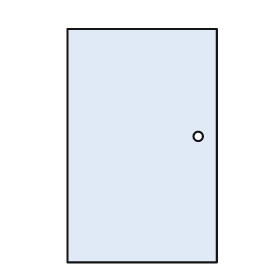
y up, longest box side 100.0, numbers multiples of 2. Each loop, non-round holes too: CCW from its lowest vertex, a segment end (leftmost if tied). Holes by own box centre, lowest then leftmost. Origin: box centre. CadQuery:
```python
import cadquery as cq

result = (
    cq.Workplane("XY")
    .moveTo(-32.0, -50.0)
    .lineTo(32.0, -50.0)
    .lineTo(32.0, 50.0)
    .lineTo(-32.0, 50.0)
    .close()
    .moveTo(24.0, 4.0)
    .circle(2.0)
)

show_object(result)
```